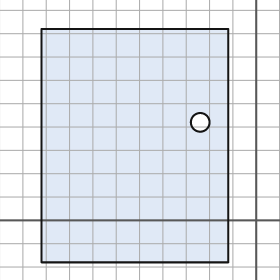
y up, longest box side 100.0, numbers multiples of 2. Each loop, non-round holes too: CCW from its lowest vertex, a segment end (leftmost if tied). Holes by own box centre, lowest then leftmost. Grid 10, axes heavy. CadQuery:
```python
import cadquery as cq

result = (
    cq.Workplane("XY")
    .moveTo(-92.0, -18.0)
    .lineTo(-12.0, -18.0)
    .lineTo(-12.0, 82.0)
    .lineTo(-92.0, 82.0)
    .close()
    .moveTo(-24.0, 42.0)
    .circle(4.0)
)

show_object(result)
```